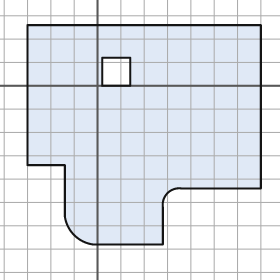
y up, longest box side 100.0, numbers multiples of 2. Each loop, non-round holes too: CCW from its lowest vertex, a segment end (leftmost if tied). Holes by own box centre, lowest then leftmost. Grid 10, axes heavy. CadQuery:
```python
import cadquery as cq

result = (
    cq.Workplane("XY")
    .moveTo(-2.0, -68.0)
    .lineTo(28.0, -68.0)
    .lineTo(28.0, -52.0)
    .threePointArc((30.0, -46.0), (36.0, -44.0))
    .lineTo(70.0, -44.0)
    .lineTo(70.0, 26.0)
    .lineTo(-30.0, 26.0)
    .lineTo(-30.0, -34.0)
    .lineTo(-14.0, -34.0)
    .lineTo(-14.0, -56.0)
    .threePointArc((-10.0, -64.0), (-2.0, -68.0))
    .close()
    .moveTo(2.0, 0.0)
    .lineTo(14.0, 0.0)
    .lineTo(14.0, 12.0)
    .lineTo(2.0, 12.0)
    .close()
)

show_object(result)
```